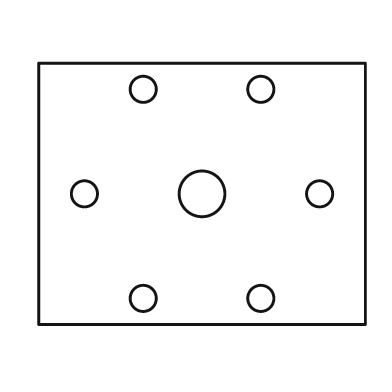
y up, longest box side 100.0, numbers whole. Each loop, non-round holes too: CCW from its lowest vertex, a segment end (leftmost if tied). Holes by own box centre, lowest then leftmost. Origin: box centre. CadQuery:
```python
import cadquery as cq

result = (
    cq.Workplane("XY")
    .moveTo(-50.0, -40.0)
    .lineTo(50.0, -40.0)
    .lineTo(50.0, 40.0)
    .lineTo(-50.0, 40.0)
    .close()
    .moveTo(-18.0, -32.0)
    .circle(4.0)
    .moveTo(18.0, -32.0)
    .circle(4.0)
    .moveTo(-36.0, 0.0)
    .circle(4.0)
    .moveTo(0.0, 0.0)
    .circle(7.0)
    .moveTo(36.0, 0.0)
    .circle(4.0)
    .moveTo(-18.0, 32.0)
    .circle(4.0)
    .moveTo(18.0, 32.0)
    .circle(4.0)
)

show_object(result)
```